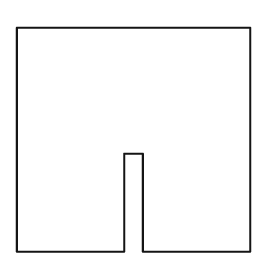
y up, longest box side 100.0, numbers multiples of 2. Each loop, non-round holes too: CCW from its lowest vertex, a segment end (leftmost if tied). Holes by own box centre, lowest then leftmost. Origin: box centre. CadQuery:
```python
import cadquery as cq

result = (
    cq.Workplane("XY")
    .moveTo(-50.0, -48.0)
    .lineTo(-4.0, -48.0)
    .lineTo(-4.0, -6.0)
    .lineTo(4.0, -6.0)
    .lineTo(4.0, -48.0)
    .lineTo(50.0, -48.0)
    .lineTo(50.0, 48.0)
    .lineTo(-50.0, 48.0)
    .close()
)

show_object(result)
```